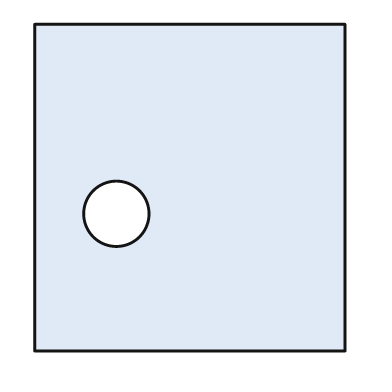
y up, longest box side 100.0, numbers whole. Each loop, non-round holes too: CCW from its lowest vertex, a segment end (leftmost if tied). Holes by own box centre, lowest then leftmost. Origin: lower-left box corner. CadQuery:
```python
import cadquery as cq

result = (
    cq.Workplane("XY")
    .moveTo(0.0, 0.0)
    .lineTo(95.0, 0.0)
    .lineTo(95.0, 100.0)
    .lineTo(0.0, 100.0)
    .close()
    .moveTo(25.0, 42.0)
    .circle(10.0)
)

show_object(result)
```